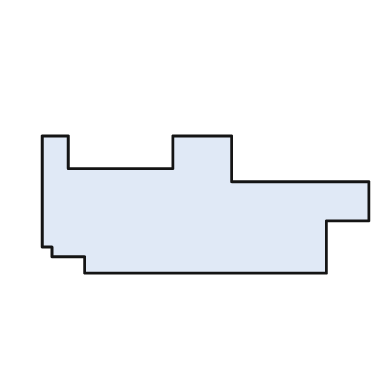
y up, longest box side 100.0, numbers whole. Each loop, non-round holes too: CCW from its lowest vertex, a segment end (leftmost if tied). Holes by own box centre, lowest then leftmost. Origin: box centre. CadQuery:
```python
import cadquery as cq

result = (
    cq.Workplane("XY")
    .moveTo(-37.0, -21.0)
    .lineTo(37.0, -21.0)
    .lineTo(37.0, -5.0)
    .lineTo(50.0, -5.0)
    .lineTo(50.0, 7.0)
    .lineTo(8.0, 7.0)
    .lineTo(8.0, 21.0)
    .lineTo(-10.0, 21.0)
    .lineTo(-10.0, 11.0)
    .lineTo(-42.0, 11.0)
    .lineTo(-42.0, 21.0)
    .lineTo(-50.0, 21.0)
    .lineTo(-50.0, -13.0)
    .lineTo(-47.0, -13.0)
    .lineTo(-47.0, -16.0)
    .lineTo(-37.0, -16.0)
    .close()
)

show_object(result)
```